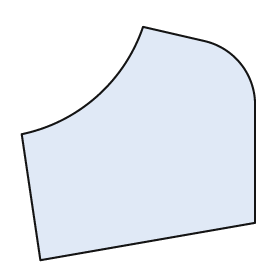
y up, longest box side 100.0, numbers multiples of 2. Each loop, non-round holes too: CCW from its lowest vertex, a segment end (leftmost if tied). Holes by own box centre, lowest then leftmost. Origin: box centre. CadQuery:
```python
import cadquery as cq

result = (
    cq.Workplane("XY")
    .moveTo(-42.0, -50.0)
    .lineTo(50.0, -34.0)
    .lineTo(50.0, 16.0)
    .threePointArc((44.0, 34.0), (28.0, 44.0))
    .lineTo(2.0, 50.0)
    .threePointArc((-18.0, 20.0), (-50.0, 4.0))
    .close()
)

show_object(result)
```